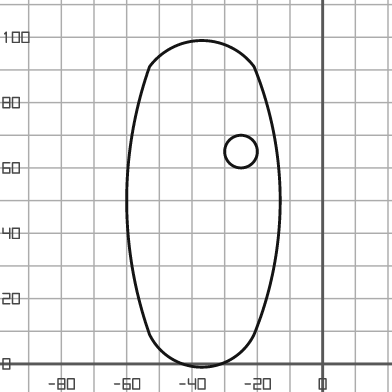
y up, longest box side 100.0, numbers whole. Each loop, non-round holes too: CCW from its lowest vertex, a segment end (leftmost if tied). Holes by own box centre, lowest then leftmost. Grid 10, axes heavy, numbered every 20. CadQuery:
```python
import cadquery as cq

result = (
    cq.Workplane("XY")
    .moveTo(-53.0, 9.0)
    .threePointArc((-37.0, -1.0), (-21.0, 9.0))
    .threePointArc((-13.0, 50.0), (-21.0, 91.0))
    .threePointArc((-37.0, 99.0), (-53.0, 91.0))
    .threePointArc((-60.0, 50.0), (-53.0, 9.0))
    .close()
    .moveTo(-25.0, 65.0)
    .circle(5.0)
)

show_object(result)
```